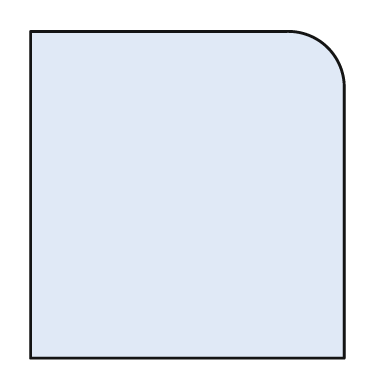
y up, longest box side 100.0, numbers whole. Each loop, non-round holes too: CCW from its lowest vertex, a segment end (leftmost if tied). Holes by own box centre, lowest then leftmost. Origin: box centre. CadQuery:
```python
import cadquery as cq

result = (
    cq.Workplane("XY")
    .moveTo(-48.0, -50.0)
    .lineTo(48.0, -50.0)
    .lineTo(48.0, 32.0)
    .threePointArc((43.0, 45.0), (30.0, 50.0))
    .lineTo(-48.0, 50.0)
    .close()
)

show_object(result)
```